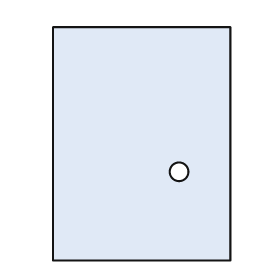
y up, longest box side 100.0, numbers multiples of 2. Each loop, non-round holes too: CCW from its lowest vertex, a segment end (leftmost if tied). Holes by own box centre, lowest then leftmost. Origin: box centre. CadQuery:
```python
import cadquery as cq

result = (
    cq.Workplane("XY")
    .moveTo(-38.0, -50.0)
    .lineTo(38.0, -50.0)
    .lineTo(38.0, 50.0)
    .lineTo(-38.0, 50.0)
    .close()
    .moveTo(16.0, -12.0)
    .circle(4.0)
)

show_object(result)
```